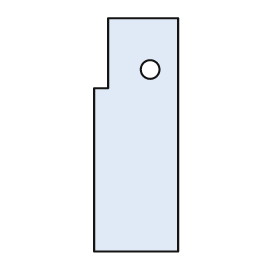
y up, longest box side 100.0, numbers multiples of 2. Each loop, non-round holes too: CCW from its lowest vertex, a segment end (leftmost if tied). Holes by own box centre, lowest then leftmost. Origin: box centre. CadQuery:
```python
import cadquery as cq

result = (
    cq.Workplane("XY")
    .moveTo(-18.0, -50.0)
    .lineTo(18.0, -50.0)
    .lineTo(18.0, 50.0)
    .lineTo(-12.0, 50.0)
    .lineTo(-12.0, 20.0)
    .lineTo(-18.0, 20.0)
    .close()
    .moveTo(6.0, 28.0)
    .circle(4.0)
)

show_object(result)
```